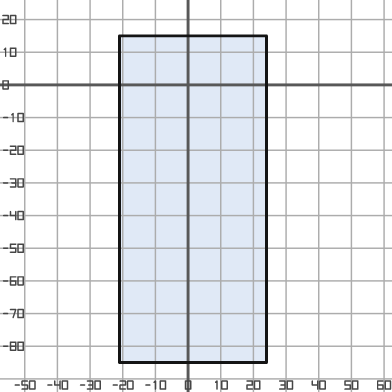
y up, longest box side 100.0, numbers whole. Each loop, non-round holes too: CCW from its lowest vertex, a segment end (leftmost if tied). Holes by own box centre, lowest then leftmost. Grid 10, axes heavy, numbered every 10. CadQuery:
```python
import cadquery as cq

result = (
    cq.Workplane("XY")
    .moveTo(-21.0, -85.0)
    .lineTo(24.0, -85.0)
    .lineTo(24.0, 15.0)
    .lineTo(-21.0, 15.0)
    .close()
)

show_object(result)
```